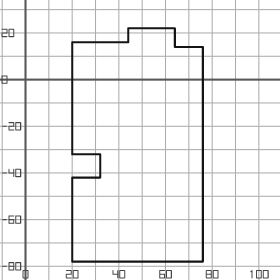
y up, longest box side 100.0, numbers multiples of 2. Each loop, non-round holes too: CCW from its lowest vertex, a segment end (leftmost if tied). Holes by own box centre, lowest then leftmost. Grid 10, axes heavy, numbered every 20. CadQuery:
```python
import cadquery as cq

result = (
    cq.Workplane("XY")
    .moveTo(20.0, -78.0)
    .lineTo(76.0, -78.0)
    .lineTo(76.0, 14.0)
    .lineTo(64.0, 14.0)
    .lineTo(64.0, 22.0)
    .lineTo(44.0, 22.0)
    .lineTo(44.0, 16.0)
    .lineTo(20.0, 16.0)
    .lineTo(20.0, -32.0)
    .lineTo(32.0, -32.0)
    .lineTo(32.0, -42.0)
    .lineTo(20.0, -42.0)
    .close()
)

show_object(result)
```